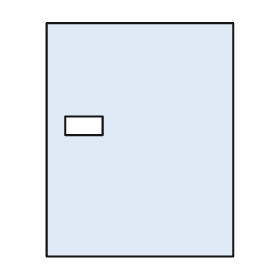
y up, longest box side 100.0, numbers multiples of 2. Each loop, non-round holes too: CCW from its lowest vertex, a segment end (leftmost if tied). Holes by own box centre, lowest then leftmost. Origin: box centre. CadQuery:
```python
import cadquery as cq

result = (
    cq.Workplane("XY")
    .moveTo(-40.0, -50.0)
    .lineTo(40.0, -50.0)
    .lineTo(40.0, 50.0)
    .lineTo(-40.0, 50.0)
    .close()
    .moveTo(-32.0, 2.0)
    .lineTo(-16.0, 2.0)
    .lineTo(-16.0, 10.0)
    .lineTo(-32.0, 10.0)
    .close()
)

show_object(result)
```